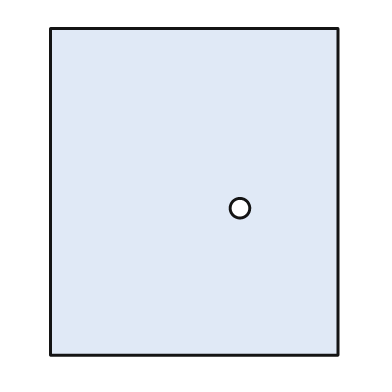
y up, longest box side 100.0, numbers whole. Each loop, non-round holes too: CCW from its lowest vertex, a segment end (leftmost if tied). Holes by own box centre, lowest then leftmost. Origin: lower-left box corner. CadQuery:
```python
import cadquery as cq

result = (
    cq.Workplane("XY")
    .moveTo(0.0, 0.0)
    .lineTo(88.0, 0.0)
    .lineTo(88.0, 100.0)
    .lineTo(0.0, 100.0)
    .close()
    .moveTo(58.0, 45.0)
    .circle(3.0)
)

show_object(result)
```